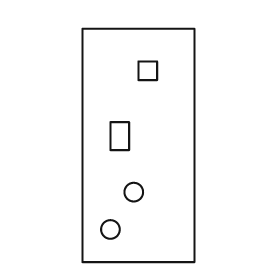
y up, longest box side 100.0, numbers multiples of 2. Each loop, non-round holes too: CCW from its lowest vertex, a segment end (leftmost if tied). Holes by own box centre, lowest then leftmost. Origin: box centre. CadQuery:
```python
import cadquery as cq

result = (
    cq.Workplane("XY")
    .moveTo(-24.0, -50.0)
    .lineTo(24.0, -50.0)
    .lineTo(24.0, 50.0)
    .lineTo(-24.0, 50.0)
    .close()
    .moveTo(-12.0, -36.0)
    .circle(4.0)
    .moveTo(-2.0, -20.0)
    .circle(4.0)
    .moveTo(-12.0, -2.0)
    .lineTo(-4.0, -2.0)
    .lineTo(-4.0, 10.0)
    .lineTo(-12.0, 10.0)
    .close()
    .moveTo(0.0, 28.0)
    .lineTo(8.0, 28.0)
    .lineTo(8.0, 36.0)
    .lineTo(0.0, 36.0)
    .close()
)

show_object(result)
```